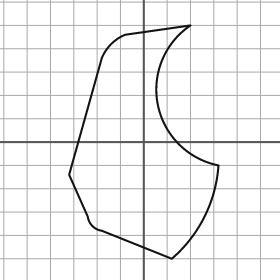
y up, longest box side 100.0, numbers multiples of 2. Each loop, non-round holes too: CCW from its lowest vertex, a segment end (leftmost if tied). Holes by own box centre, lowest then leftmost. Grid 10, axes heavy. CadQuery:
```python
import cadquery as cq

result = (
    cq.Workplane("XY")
    .moveTo(12.0, -50.0)
    .threePointArc((26.0, -32.0), (32.0, -10.0))
    .threePointArc((6.0, 16.0), (20.0, 50.0))
    .lineTo(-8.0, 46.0)
    .threePointArc((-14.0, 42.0), (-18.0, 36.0))
    .lineTo(-32.0, -14.0)
    .lineTo(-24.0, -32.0)
    .threePointArc((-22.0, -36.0), (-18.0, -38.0))
    .close()
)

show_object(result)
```